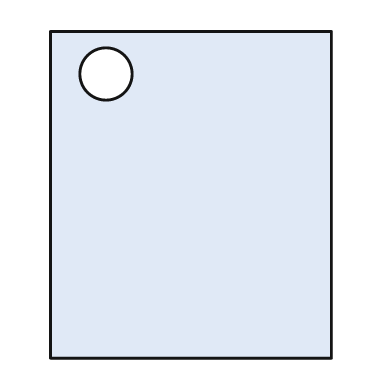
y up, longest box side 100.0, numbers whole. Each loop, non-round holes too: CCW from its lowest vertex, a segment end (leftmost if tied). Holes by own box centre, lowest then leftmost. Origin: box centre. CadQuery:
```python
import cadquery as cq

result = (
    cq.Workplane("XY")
    .moveTo(-43.0, -50.0)
    .lineTo(43.0, -50.0)
    .lineTo(43.0, 50.0)
    .lineTo(-43.0, 50.0)
    .close()
    .moveTo(-26.0, 37.0)
    .circle(8.0)
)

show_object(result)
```